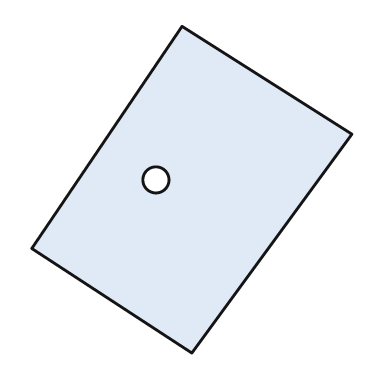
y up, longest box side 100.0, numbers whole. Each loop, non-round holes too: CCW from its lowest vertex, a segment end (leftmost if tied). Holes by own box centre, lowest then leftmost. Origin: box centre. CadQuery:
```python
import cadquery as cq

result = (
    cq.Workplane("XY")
    .moveTo(0.0, -50.0)
    .lineTo(49.0, 17.0)
    .lineTo(-3.0, 50.0)
    .lineTo(-49.0, -18.0)
    .close()
    .moveTo(-11.0, 3.0)
    .circle(4.0)
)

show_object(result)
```